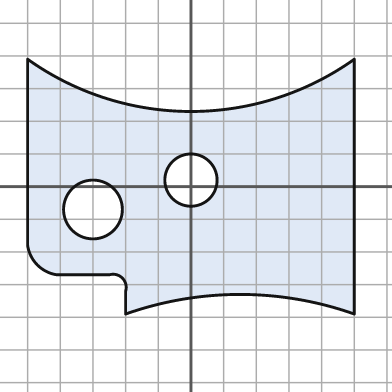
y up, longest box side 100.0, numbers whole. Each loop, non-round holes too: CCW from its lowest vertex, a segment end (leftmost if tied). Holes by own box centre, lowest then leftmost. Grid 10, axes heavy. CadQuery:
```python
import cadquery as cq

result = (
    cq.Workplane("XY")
    .moveTo(-20.0, -39.0)
    .threePointArc((15.0, -33.0), (50.0, -39.0))
    .lineTo(50.0, 39.0)
    .threePointArc((0.0, 23.0), (-50.0, 39.0))
    .lineTo(-50.0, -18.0)
    .threePointArc((-47.0, -24.0), (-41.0, -27.0))
    .lineTo(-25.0, -27.0)
    .threePointArc((-21.0, -28.0), (-20.0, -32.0))
    .close()
    .moveTo(-30.0, -7.0)
    .circle(9.0)
    .moveTo(0.0, 2.0)
    .circle(8.0)
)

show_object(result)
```